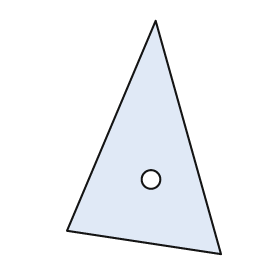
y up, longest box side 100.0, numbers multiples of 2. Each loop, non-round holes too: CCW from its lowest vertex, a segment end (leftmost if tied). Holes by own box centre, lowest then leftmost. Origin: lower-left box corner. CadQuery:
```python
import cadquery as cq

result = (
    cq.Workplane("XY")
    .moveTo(66.0, 0.0)
    .lineTo(38.0, 100.0)
    .lineTo(0.0, 10.0)
    .close()
    .moveTo(36.0, 32.0)
    .circle(4.0)
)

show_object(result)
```